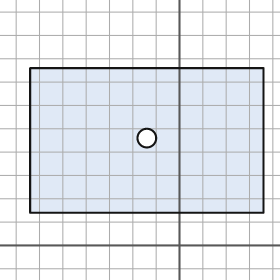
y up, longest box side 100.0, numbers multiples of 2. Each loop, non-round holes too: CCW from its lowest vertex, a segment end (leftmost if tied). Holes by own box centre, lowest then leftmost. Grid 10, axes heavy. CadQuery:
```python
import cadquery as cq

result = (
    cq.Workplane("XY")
    .moveTo(-64.0, 14.0)
    .lineTo(36.0, 14.0)
    .lineTo(36.0, 76.0)
    .lineTo(-64.0, 76.0)
    .close()
    .moveTo(-14.0, 46.0)
    .circle(4.0)
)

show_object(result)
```